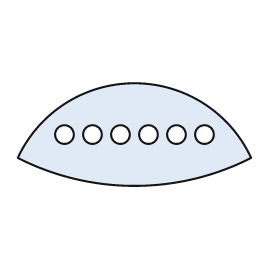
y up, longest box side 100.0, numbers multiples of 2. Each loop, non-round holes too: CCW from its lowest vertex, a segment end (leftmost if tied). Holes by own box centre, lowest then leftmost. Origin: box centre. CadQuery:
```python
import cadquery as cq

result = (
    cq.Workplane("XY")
    .moveTo(-50.0, -10.0)
    .threePointArc((0.0, -22.0), (50.0, -10.0))
    .threePointArc((0.0, 22.0), (-50.0, -10.0))
    .close()
    .moveTo(-30.0, 0.0)
    .circle(4.0)
    .moveTo(-18.0, 0.0)
    .circle(4.0)
    .moveTo(-6.0, 0.0)
    .circle(4.0)
    .moveTo(6.0, 0.0)
    .circle(4.0)
    .moveTo(18.0, 0.0)
    .circle(4.0)
    .moveTo(30.0, 0.0)
    .circle(4.0)
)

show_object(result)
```